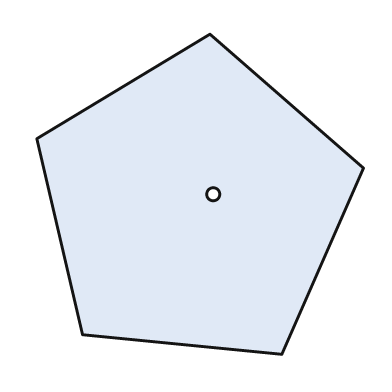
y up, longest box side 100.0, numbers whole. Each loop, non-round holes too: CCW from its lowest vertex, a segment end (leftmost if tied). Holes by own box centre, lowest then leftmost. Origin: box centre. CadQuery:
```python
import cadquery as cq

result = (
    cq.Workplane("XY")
    .moveTo(25.0, -49.0)
    .lineTo(50.0, 8.0)
    .lineTo(3.0, 49.0)
    .lineTo(-50.0, 17.0)
    .lineTo(-36.0, -43.0)
    .close()
    .moveTo(4.0, 0.0)
    .circle(2.0)
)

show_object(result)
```